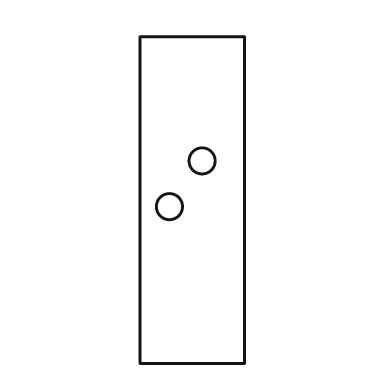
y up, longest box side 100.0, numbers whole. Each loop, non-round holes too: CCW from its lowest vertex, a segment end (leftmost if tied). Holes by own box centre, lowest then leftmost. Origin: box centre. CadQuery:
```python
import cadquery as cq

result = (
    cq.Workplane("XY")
    .moveTo(-16.0, -50.0)
    .lineTo(16.0, -50.0)
    .lineTo(16.0, 50.0)
    .lineTo(-16.0, 50.0)
    .close()
    .moveTo(-7.0, -2.0)
    .circle(4.0)
    .moveTo(3.0, 12.0)
    .circle(4.0)
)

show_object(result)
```